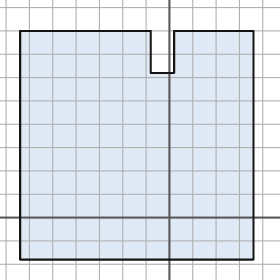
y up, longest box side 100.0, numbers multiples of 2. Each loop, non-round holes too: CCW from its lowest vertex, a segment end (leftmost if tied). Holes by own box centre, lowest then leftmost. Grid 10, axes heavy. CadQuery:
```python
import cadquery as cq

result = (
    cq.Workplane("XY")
    .moveTo(-64.0, -18.0)
    .lineTo(36.0, -18.0)
    .lineTo(36.0, 80.0)
    .lineTo(2.0, 80.0)
    .lineTo(2.0, 62.0)
    .lineTo(-8.0, 62.0)
    .lineTo(-8.0, 80.0)
    .lineTo(-64.0, 80.0)
    .close()
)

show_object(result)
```